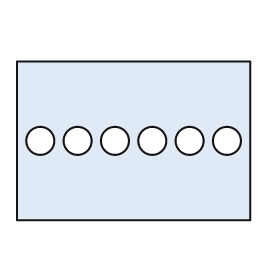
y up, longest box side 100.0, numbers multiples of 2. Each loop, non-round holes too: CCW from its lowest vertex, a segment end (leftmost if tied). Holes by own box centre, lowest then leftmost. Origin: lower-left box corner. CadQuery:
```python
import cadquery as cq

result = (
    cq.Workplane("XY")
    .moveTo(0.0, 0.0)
    .lineTo(100.0, 0.0)
    .lineTo(100.0, 68.0)
    .lineTo(0.0, 68.0)
    .close()
    .moveTo(10.0, 34.0)
    .circle(6.0)
    .moveTo(26.0, 34.0)
    .circle(6.0)
    .moveTo(42.0, 34.0)
    .circle(6.0)
    .moveTo(58.0, 34.0)
    .circle(6.0)
    .moveTo(74.0, 34.0)
    .circle(6.0)
    .moveTo(90.0, 34.0)
    .circle(6.0)
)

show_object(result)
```